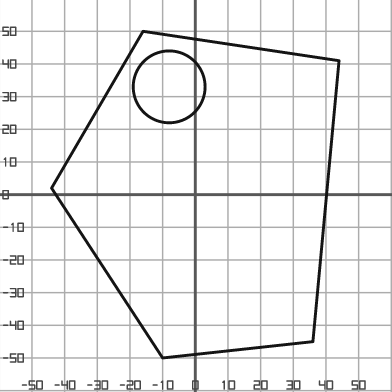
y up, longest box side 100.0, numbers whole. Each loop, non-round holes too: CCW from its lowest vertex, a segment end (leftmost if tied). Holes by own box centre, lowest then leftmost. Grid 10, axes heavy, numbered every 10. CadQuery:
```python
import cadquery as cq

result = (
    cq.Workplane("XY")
    .moveTo(-10.0, -50.0)
    .lineTo(36.0, -45.0)
    .lineTo(44.0, 41.0)
    .lineTo(-16.0, 50.0)
    .lineTo(-44.0, 2.0)
    .close()
    .moveTo(-8.0, 33.0)
    .circle(11.0)
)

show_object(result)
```